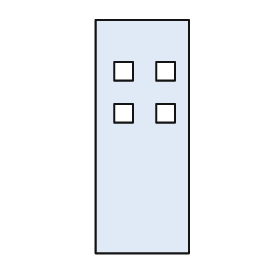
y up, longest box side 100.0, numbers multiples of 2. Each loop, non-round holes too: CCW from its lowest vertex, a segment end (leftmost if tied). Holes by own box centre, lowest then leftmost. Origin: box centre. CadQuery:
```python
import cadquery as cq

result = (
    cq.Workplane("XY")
    .moveTo(-20.0, -50.0)
    .lineTo(20.0, -50.0)
    .lineTo(20.0, 50.0)
    .lineTo(-20.0, 50.0)
    .close()
    .moveTo(-12.0, 6.0)
    .lineTo(-4.0, 6.0)
    .lineTo(-4.0, 14.0)
    .lineTo(-12.0, 14.0)
    .close()
    .moveTo(6.0, 6.0)
    .lineTo(14.0, 6.0)
    .lineTo(14.0, 14.0)
    .lineTo(6.0, 14.0)
    .close()
    .moveTo(-12.0, 24.0)
    .lineTo(-4.0, 24.0)
    .lineTo(-4.0, 32.0)
    .lineTo(-12.0, 32.0)
    .close()
    .moveTo(6.0, 24.0)
    .lineTo(14.0, 24.0)
    .lineTo(14.0, 32.0)
    .lineTo(6.0, 32.0)
    .close()
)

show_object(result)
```